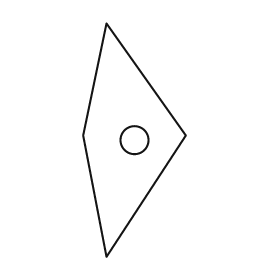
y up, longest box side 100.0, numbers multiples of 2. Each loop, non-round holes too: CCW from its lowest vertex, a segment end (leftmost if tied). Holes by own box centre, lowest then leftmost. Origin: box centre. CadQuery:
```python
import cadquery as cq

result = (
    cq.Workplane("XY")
    .moveTo(-12.0, -50.0)
    .lineTo(22.0, 2.0)
    .lineTo(-12.0, 50.0)
    .lineTo(-22.0, 2.0)
    .close()
    .moveTo(0.0, 0.0)
    .circle(6.0)
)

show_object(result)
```